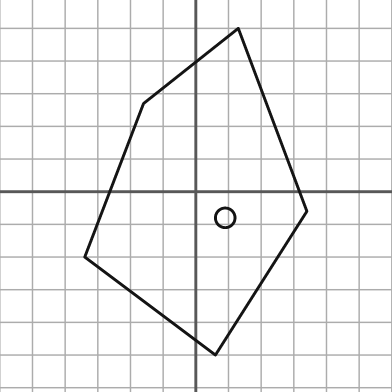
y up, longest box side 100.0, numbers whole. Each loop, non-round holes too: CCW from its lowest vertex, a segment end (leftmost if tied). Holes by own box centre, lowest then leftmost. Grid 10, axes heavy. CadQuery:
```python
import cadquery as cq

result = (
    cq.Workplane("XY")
    .moveTo(6.0, -50.0)
    .lineTo(34.0, -6.0)
    .lineTo(13.0, 50.0)
    .lineTo(-16.0, 27.0)
    .lineTo(-34.0, -20.0)
    .close()
    .moveTo(9.0, -8.0)
    .circle(3.0)
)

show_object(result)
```